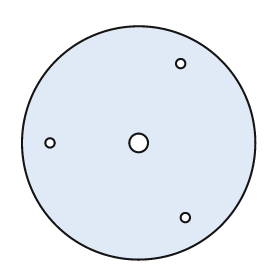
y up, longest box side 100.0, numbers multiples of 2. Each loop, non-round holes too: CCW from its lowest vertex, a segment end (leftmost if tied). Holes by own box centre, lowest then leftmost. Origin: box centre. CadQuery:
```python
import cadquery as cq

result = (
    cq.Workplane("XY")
    .moveTo(0.0, 0.0)
    .circle(50.0)
    .moveTo(20.0, -32.0)
    .circle(2.0)
    .moveTo(-38.0, 0.0)
    .circle(2.0)
    .moveTo(0.0, 0.0)
    .circle(4.0)
    .moveTo(18.0, 34.0)
    .circle(2.0)
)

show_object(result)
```